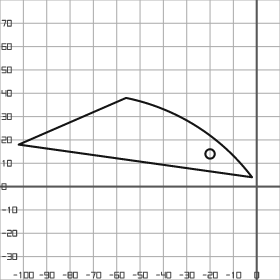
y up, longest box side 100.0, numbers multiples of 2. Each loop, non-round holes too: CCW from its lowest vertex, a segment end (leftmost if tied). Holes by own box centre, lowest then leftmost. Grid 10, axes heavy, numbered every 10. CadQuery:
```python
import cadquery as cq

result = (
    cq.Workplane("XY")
    .moveTo(-2.0, 4.0)
    .threePointArc((-26.0, 26.0), (-56.0, 38.0))
    .lineTo(-102.0, 18.0)
    .close()
    .moveTo(-20.0, 14.0)
    .circle(2.0)
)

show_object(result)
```